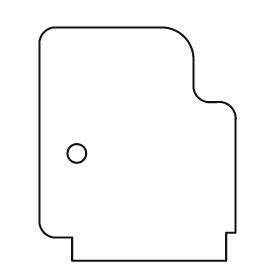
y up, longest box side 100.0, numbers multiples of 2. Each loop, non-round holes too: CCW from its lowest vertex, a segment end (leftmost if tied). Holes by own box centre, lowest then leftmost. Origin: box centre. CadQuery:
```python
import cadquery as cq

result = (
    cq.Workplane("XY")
    .moveTo(-28.0, -50.0)
    .lineTo(38.0, -50.0)
    .lineTo(38.0, -38.0)
    .lineTo(42.0, -38.0)
    .lineTo(42.0, 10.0)
    .threePointArc((40.0, 16.0), (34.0, 18.0))
    .lineTo(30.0, 18.0)
    .threePointArc((26.0, 20.0), (24.0, 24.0))
    .lineTo(24.0, 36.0)
    .threePointArc((20.0, 46.0), (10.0, 50.0))
    .lineTo(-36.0, 50.0)
    .threePointArc((-40.0, 48.0), (-42.0, 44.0))
    .lineTo(-42.0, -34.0)
    .threePointArc((-40.0, -38.0), (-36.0, -40.0))
    .lineTo(-28.0, -40.0)
    .close()
    .moveTo(-26.0, -4.0)
    .circle(4.0)
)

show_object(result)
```